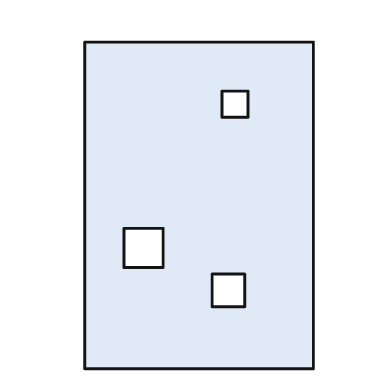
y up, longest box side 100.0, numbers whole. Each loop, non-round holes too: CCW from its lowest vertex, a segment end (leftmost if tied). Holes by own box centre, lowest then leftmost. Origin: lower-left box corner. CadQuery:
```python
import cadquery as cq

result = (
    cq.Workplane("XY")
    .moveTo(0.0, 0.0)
    .lineTo(70.0, 0.0)
    .lineTo(70.0, 100.0)
    .lineTo(0.0, 100.0)
    .close()
    .moveTo(39.0, 19.0)
    .lineTo(49.0, 19.0)
    .lineTo(49.0, 29.0)
    .lineTo(39.0, 29.0)
    .close()
    .moveTo(12.0, 31.0)
    .lineTo(24.0, 31.0)
    .lineTo(24.0, 43.0)
    .lineTo(12.0, 43.0)
    .close()
    .moveTo(42.0, 77.0)
    .lineTo(50.0, 77.0)
    .lineTo(50.0, 85.0)
    .lineTo(42.0, 85.0)
    .close()
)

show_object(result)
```